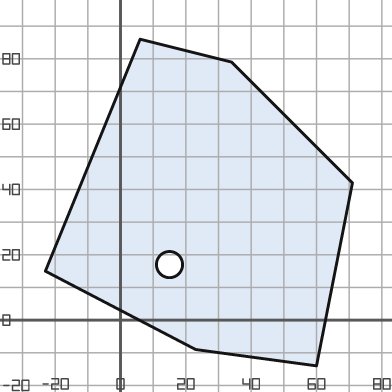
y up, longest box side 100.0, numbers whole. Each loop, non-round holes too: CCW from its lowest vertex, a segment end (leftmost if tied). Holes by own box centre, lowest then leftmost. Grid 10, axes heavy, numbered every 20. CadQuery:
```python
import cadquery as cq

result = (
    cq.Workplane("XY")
    .moveTo(60.0, -14.0)
    .lineTo(71.0, 42.0)
    .lineTo(34.0, 79.0)
    .lineTo(6.0, 86.0)
    .lineTo(-23.0, 15.0)
    .lineTo(23.0, -9.0)
    .close()
    .moveTo(15.0, 17.0)
    .circle(4.0)
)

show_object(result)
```